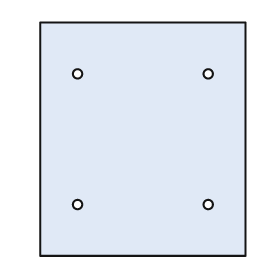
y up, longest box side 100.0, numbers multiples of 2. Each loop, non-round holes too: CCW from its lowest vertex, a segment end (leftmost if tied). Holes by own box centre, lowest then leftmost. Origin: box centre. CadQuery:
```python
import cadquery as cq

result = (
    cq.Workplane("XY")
    .moveTo(-44.0, -50.0)
    .lineTo(44.0, -50.0)
    .lineTo(44.0, 50.0)
    .lineTo(-44.0, 50.0)
    .close()
    .moveTo(-28.0, -28.0)
    .circle(2.0)
    .moveTo(28.0, -28.0)
    .circle(2.0)
    .moveTo(-28.0, 28.0)
    .circle(2.0)
    .moveTo(28.0, 28.0)
    .circle(2.0)
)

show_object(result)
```